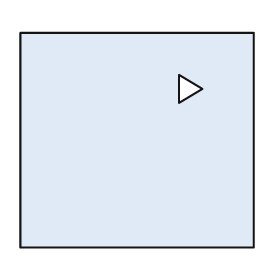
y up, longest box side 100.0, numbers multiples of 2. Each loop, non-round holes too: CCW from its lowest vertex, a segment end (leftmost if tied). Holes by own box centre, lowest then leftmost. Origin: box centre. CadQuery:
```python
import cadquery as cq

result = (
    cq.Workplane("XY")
    .moveTo(-50.0, -46.0)
    .lineTo(50.0, -46.0)
    .lineTo(50.0, 46.0)
    .lineTo(-50.0, 46.0)
    .close()
    .moveTo(18.0, 16.0)
    .lineTo(28.0, 22.0)
    .lineTo(18.0, 28.0)
    .close()
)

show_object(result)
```